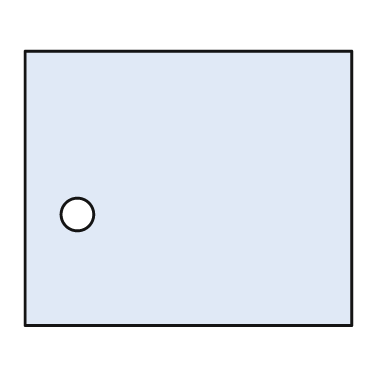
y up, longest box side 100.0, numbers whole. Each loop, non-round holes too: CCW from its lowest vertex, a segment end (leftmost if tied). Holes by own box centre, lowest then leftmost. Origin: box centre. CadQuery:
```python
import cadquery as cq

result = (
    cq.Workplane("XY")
    .moveTo(-50.0, -42.0)
    .lineTo(50.0, -42.0)
    .lineTo(50.0, 42.0)
    .lineTo(-50.0, 42.0)
    .close()
    .moveTo(-34.0, -8.0)
    .circle(5.0)
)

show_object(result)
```